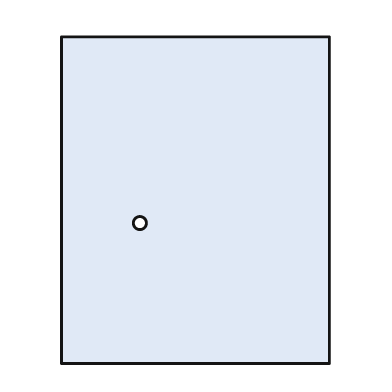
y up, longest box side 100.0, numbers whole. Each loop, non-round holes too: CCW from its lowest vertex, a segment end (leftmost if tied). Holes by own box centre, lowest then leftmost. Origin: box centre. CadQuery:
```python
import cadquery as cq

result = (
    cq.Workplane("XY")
    .moveTo(-41.0, -50.0)
    .lineTo(41.0, -50.0)
    .lineTo(41.0, 50.0)
    .lineTo(-41.0, 50.0)
    .close()
    .moveTo(-17.0, -7.0)
    .circle(2.0)
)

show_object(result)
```